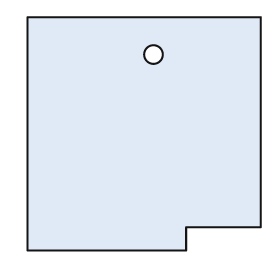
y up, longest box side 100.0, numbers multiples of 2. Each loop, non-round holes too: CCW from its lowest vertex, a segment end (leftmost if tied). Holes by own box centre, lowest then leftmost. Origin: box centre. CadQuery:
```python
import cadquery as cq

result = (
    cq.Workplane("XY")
    .moveTo(-50.0, -50.0)
    .lineTo(18.0, -50.0)
    .lineTo(18.0, -40.0)
    .lineTo(50.0, -40.0)
    .lineTo(50.0, 50.0)
    .lineTo(-50.0, 50.0)
    .close()
    .moveTo(4.0, 34.0)
    .circle(4.0)
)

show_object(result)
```